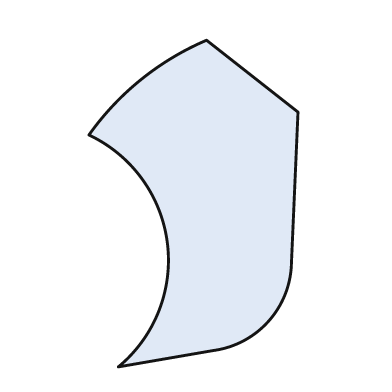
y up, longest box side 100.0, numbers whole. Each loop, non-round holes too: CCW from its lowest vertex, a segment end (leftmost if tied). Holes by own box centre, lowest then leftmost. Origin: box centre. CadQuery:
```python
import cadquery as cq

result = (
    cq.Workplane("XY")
    .moveTo(-23.0, -50.0)
    .lineTo(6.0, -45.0)
    .threePointArc((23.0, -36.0), (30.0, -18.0))
    .lineTo(32.0, 28.0)
    .lineTo(4.0, 50.0)
    .threePointArc((-16.0, 38.0), (-32.0, 21.0))
    .threePointArc((-8.0, -12.0), (-23.0, -50.0))
    .close()
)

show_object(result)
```